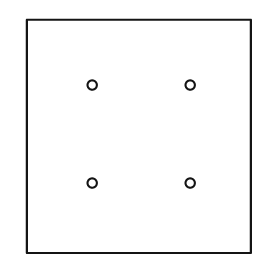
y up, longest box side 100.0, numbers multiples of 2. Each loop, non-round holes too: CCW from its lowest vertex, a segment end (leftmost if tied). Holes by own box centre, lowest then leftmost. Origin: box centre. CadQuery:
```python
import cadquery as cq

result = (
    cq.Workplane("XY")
    .moveTo(-48.0, -50.0)
    .lineTo(48.0, -50.0)
    .lineTo(48.0, 50.0)
    .lineTo(-48.0, 50.0)
    .close()
    .moveTo(-20.0, -20.0)
    .circle(2.0)
    .moveTo(22.0, -20.0)
    .circle(2.0)
    .moveTo(-20.0, 22.0)
    .circle(2.0)
    .moveTo(22.0, 22.0)
    .circle(2.0)
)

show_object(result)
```